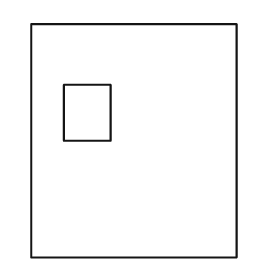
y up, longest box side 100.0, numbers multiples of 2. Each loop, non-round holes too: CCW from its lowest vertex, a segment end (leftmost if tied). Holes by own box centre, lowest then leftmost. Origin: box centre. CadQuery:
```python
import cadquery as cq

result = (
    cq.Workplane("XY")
    .moveTo(-44.0, -50.0)
    .lineTo(44.0, -50.0)
    .lineTo(44.0, 50.0)
    .lineTo(-44.0, 50.0)
    .close()
    .moveTo(-30.0, 0.0)
    .lineTo(-10.0, 0.0)
    .lineTo(-10.0, 24.0)
    .lineTo(-30.0, 24.0)
    .close()
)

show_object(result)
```